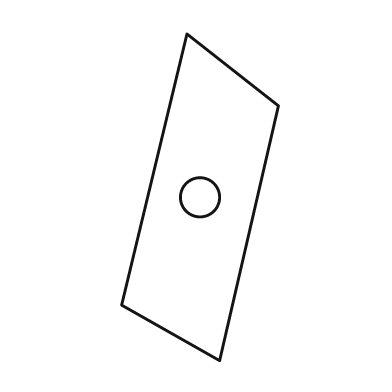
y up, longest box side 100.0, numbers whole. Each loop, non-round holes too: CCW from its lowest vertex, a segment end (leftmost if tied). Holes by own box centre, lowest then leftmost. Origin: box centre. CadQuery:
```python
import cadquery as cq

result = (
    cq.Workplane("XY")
    .moveTo(6.0, -50.0)
    .lineTo(24.0, 28.0)
    .lineTo(-4.0, 50.0)
    .lineTo(-24.0, -33.0)
    .close()
    .moveTo(0.0, 0.0)
    .circle(6.0)
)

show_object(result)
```